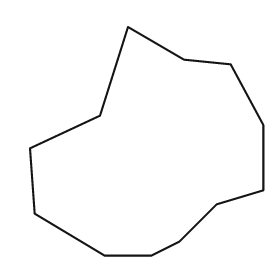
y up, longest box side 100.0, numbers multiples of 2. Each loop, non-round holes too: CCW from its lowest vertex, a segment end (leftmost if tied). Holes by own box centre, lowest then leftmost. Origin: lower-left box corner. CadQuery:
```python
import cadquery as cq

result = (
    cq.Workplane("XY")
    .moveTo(32.0, 0.0)
    .lineTo(52.0, 0.0)
    .lineTo(64.0, 6.0)
    .lineTo(80.0, 22.0)
    .lineTo(100.0, 28.0)
    .lineTo(100.0, 56.0)
    .lineTo(86.0, 82.0)
    .lineTo(66.0, 84.0)
    .lineTo(42.0, 98.0)
    .lineTo(30.0, 60.0)
    .lineTo(0.0, 46.0)
    .lineTo(2.0, 18.0)
    .close()
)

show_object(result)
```